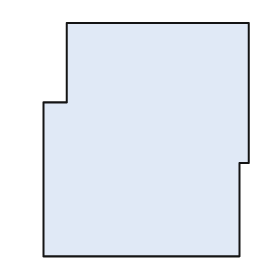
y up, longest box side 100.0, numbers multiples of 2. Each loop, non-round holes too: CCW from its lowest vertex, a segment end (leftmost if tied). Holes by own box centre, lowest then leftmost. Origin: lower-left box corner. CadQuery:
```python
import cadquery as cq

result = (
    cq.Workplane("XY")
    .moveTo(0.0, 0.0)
    .lineTo(84.0, 0.0)
    .lineTo(84.0, 40.0)
    .lineTo(88.0, 40.0)
    .lineTo(88.0, 100.0)
    .lineTo(10.0, 100.0)
    .lineTo(10.0, 66.0)
    .lineTo(0.0, 66.0)
    .close()
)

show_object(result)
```